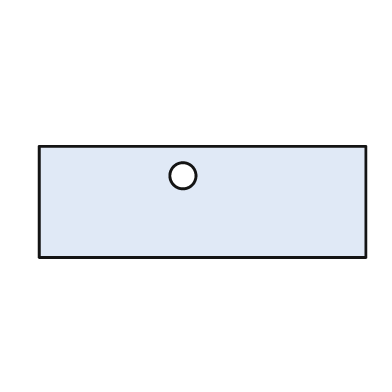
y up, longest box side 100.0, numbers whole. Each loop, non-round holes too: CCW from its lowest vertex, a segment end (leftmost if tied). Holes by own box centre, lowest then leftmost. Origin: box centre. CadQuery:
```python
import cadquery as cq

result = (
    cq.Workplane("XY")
    .moveTo(-50.0, -17.0)
    .lineTo(50.0, -17.0)
    .lineTo(50.0, 17.0)
    .lineTo(-50.0, 17.0)
    .close()
    .moveTo(-6.0, 8.0)
    .circle(4.0)
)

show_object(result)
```